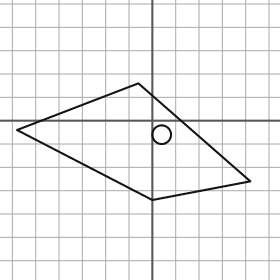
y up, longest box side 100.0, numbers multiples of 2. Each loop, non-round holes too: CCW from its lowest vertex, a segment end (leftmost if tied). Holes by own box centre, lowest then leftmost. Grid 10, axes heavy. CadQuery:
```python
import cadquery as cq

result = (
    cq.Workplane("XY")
    .moveTo(0.0, -34.0)
    .lineTo(42.0, -26.0)
    .lineTo(-6.0, 16.0)
    .lineTo(-58.0, -4.0)
    .close()
    .moveTo(4.0, -6.0)
    .circle(4.0)
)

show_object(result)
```